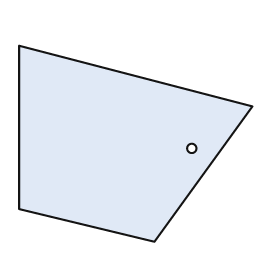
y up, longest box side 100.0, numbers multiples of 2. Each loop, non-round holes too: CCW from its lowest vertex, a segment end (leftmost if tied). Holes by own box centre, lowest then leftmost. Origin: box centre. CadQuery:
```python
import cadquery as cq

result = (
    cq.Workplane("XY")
    .moveTo(8.0, -42.0)
    .lineTo(50.0, 16.0)
    .lineTo(-50.0, 42.0)
    .lineTo(-50.0, -28.0)
    .close()
    .moveTo(24.0, -2.0)
    .circle(2.0)
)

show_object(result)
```